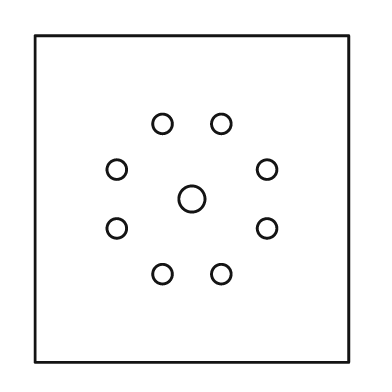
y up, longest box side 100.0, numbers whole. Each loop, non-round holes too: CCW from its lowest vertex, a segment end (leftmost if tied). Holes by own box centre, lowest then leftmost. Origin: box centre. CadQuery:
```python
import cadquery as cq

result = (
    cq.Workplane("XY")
    .moveTo(-48.0, -50.0)
    .lineTo(48.0, -50.0)
    .lineTo(48.0, 50.0)
    .lineTo(-48.0, 50.0)
    .close()
    .moveTo(-9.0, -23.0)
    .circle(3.0)
    .moveTo(9.0, -23.0)
    .circle(3.0)
    .moveTo(-23.0, -9.0)
    .circle(3.0)
    .moveTo(23.0, -9.0)
    .circle(3.0)
    .moveTo(0.0, 0.0)
    .circle(4.0)
    .moveTo(-23.0, 9.0)
    .circle(3.0)
    .moveTo(23.0, 9.0)
    .circle(3.0)
    .moveTo(-9.0, 23.0)
    .circle(3.0)
    .moveTo(9.0, 23.0)
    .circle(3.0)
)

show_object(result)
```